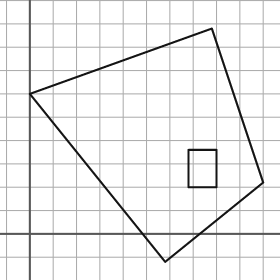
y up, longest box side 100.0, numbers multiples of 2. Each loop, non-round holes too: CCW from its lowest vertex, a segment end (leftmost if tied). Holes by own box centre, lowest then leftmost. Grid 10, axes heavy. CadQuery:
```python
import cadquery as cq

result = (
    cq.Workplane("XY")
    .moveTo(58.0, -12.0)
    .lineTo(100.0, 22.0)
    .lineTo(78.0, 88.0)
    .lineTo(0.0, 60.0)
    .close()
    .moveTo(68.0, 20.0)
    .lineTo(80.0, 20.0)
    .lineTo(80.0, 36.0)
    .lineTo(68.0, 36.0)
    .close()
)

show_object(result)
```